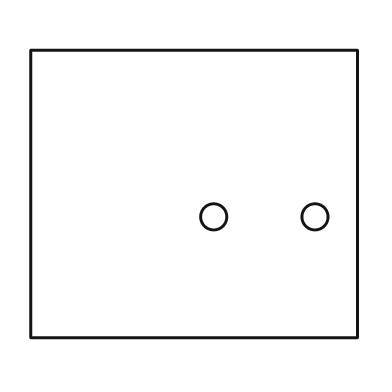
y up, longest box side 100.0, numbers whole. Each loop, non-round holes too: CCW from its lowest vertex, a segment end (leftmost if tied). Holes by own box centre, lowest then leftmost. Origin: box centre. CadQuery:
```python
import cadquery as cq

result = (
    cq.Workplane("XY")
    .moveTo(-50.0, -44.0)
    .lineTo(50.0, -44.0)
    .lineTo(50.0, 44.0)
    .lineTo(-50.0, 44.0)
    .close()
    .moveTo(6.0, -7.0)
    .circle(4.0)
    .moveTo(37.0, -7.0)
    .circle(4.0)
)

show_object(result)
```